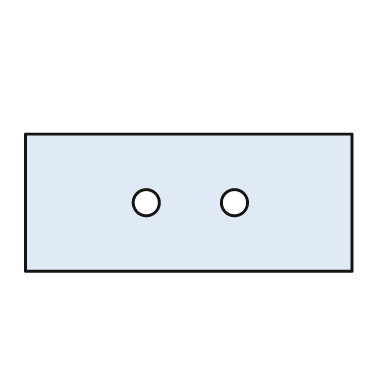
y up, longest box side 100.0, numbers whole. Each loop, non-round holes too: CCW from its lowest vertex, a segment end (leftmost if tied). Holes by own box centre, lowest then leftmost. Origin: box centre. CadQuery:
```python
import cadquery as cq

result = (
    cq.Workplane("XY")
    .moveTo(-50.0, -21.0)
    .lineTo(50.0, -21.0)
    .lineTo(50.0, 21.0)
    .lineTo(-50.0, 21.0)
    .close()
    .moveTo(-13.0, 0.0)
    .circle(4.0)
    .moveTo(14.0, 0.0)
    .circle(4.0)
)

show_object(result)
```